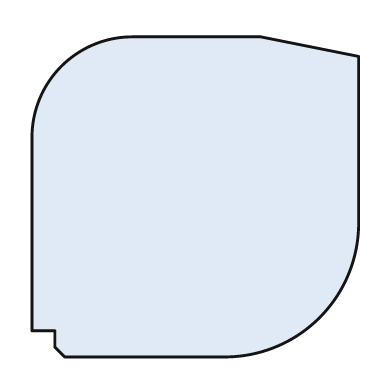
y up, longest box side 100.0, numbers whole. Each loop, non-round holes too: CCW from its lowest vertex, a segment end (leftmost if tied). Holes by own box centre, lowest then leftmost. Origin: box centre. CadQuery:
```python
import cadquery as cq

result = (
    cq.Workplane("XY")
    .moveTo(-40.0, -49.0)
    .lineTo(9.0, -49.0)
    .threePointArc((38.0, -37.0), (50.0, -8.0))
    .lineTo(50.0, 43.0)
    .lineTo(20.0, 49.0)
    .lineTo(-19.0, 49.0)
    .threePointArc((-41.0, 40.0), (-50.0, 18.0))
    .lineTo(-50.0, -41.0)
    .lineTo(-43.0, -41.0)
    .lineTo(-43.0, -46.0)
    .close()
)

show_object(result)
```